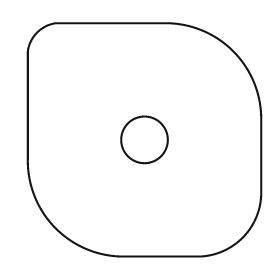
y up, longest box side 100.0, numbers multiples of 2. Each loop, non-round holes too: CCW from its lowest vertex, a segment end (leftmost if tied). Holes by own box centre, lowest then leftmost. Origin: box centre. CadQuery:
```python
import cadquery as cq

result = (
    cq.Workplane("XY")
    .moveTo(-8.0, -50.0)
    .lineTo(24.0, -50.0)
    .threePointArc((42.0, -42.0), (50.0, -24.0))
    .lineTo(50.0, 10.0)
    .threePointArc((38.0, 38.0), (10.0, 50.0))
    .lineTo(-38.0, 50.0)
    .threePointArc((-46.0, 46.0), (-50.0, 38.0))
    .lineTo(-50.0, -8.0)
    .threePointArc((-38.0, -38.0), (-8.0, -50.0))
    .close()
    .moveTo(0.0, 0.0)
    .circle(10.0)
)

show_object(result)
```